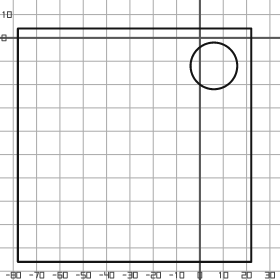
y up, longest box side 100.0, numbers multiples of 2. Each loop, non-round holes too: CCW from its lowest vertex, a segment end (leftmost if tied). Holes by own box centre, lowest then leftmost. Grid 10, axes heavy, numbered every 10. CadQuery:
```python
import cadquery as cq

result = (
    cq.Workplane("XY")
    .moveTo(-78.0, -96.0)
    .lineTo(22.0, -96.0)
    .lineTo(22.0, 4.0)
    .lineTo(-78.0, 4.0)
    .close()
    .moveTo(6.0, -12.0)
    .circle(10.0)
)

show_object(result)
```